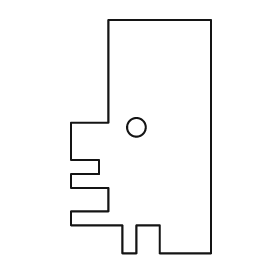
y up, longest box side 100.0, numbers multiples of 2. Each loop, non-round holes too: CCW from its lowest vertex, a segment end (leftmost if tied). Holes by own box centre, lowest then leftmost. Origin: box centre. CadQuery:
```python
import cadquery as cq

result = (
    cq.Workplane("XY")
    .moveTo(-8.0, -50.0)
    .lineTo(-2.0, -50.0)
    .lineTo(-2.0, -38.0)
    .lineTo(8.0, -38.0)
    .lineTo(8.0, -50.0)
    .lineTo(30.0, -50.0)
    .lineTo(30.0, 50.0)
    .lineTo(-14.0, 50.0)
    .lineTo(-14.0, 6.0)
    .lineTo(-30.0, 6.0)
    .lineTo(-30.0, -10.0)
    .lineTo(-18.0, -10.0)
    .lineTo(-18.0, -16.0)
    .lineTo(-30.0, -16.0)
    .lineTo(-30.0, -22.0)
    .lineTo(-14.0, -22.0)
    .lineTo(-14.0, -32.0)
    .lineTo(-30.0, -32.0)
    .lineTo(-30.0, -38.0)
    .lineTo(-8.0, -38.0)
    .close()
    .moveTo(-2.0, 4.0)
    .circle(4.0)
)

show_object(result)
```